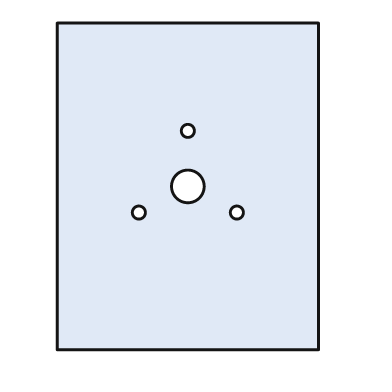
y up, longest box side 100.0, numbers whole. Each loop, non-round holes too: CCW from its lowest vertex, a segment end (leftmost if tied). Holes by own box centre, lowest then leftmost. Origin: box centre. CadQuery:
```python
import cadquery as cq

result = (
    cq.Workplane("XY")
    .moveTo(-40.0, -50.0)
    .lineTo(40.0, -50.0)
    .lineTo(40.0, 50.0)
    .lineTo(-40.0, 50.0)
    .close()
    .moveTo(-15.0, -8.0)
    .circle(2.0)
    .moveTo(15.0, -8.0)
    .circle(2.0)
    .moveTo(0.0, 0.0)
    .circle(5.0)
    .moveTo(0.0, 17.0)
    .circle(2.0)
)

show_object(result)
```